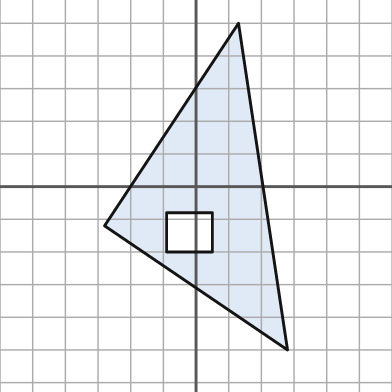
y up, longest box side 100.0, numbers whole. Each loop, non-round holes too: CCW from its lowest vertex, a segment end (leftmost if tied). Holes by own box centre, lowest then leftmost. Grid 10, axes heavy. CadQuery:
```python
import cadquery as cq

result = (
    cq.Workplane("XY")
    .moveTo(28.0, -50.0)
    .lineTo(13.0, 50.0)
    .lineTo(-28.0, -12.0)
    .close()
    .moveTo(-9.0, -20.0)
    .lineTo(5.0, -20.0)
    .lineTo(5.0, -8.0)
    .lineTo(-9.0, -8.0)
    .close()
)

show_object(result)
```